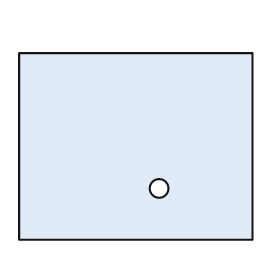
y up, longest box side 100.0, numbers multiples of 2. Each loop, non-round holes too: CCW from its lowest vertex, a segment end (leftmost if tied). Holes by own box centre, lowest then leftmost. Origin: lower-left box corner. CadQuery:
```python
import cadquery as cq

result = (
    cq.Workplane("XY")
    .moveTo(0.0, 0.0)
    .lineTo(100.0, 0.0)
    .lineTo(100.0, 80.0)
    .lineTo(0.0, 80.0)
    .close()
    .moveTo(60.0, 22.0)
    .circle(4.0)
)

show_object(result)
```